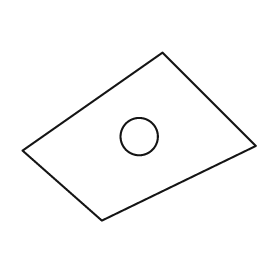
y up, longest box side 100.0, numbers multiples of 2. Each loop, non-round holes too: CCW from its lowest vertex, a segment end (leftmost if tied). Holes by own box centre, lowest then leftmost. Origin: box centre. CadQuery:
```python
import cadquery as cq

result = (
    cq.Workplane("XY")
    .moveTo(-16.0, -36.0)
    .lineTo(50.0, -4.0)
    .lineTo(10.0, 36.0)
    .lineTo(-50.0, -6.0)
    .close()
    .moveTo(0.0, 0.0)
    .circle(8.0)
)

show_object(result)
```